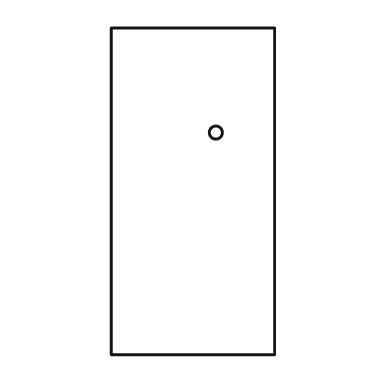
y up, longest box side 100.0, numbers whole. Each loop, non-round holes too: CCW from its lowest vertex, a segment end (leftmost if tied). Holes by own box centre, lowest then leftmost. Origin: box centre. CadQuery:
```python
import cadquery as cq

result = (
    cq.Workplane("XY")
    .moveTo(-25.0, -50.0)
    .lineTo(25.0, -50.0)
    .lineTo(25.0, 50.0)
    .lineTo(-25.0, 50.0)
    .close()
    .moveTo(7.0, 18.0)
    .circle(2.0)
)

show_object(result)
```